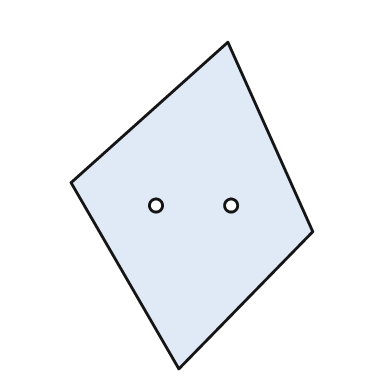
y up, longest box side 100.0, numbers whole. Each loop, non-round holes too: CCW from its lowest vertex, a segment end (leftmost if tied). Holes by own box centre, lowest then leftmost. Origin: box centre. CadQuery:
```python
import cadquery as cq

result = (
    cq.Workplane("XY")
    .moveTo(-4.0, -50.0)
    .lineTo(37.0, -8.0)
    .lineTo(11.0, 50.0)
    .lineTo(-37.0, 7.0)
    .close()
    .moveTo(-11.0, 0.0)
    .circle(2.0)
    .moveTo(12.0, 0.0)
    .circle(2.0)
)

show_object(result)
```